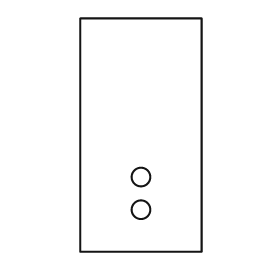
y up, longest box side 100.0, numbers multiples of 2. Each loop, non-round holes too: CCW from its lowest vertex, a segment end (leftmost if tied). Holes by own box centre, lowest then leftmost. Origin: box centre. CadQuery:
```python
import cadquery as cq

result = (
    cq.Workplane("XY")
    .moveTo(-26.0, -50.0)
    .lineTo(26.0, -50.0)
    .lineTo(26.0, 50.0)
    .lineTo(-26.0, 50.0)
    .close()
    .moveTo(0.0, -32.0)
    .circle(4.0)
    .moveTo(0.0, -18.0)
    .circle(4.0)
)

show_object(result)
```